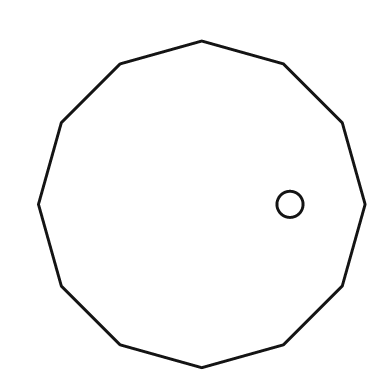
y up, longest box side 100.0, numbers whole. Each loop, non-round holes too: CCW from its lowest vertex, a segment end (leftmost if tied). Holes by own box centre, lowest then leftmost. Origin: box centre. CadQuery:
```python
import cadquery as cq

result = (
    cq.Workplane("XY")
    .moveTo(0.0, -50.0)
    .lineTo(25.0, -43.0)
    .lineTo(43.0, -25.0)
    .lineTo(50.0, 0.0)
    .lineTo(43.0, 25.0)
    .lineTo(25.0, 43.0)
    .lineTo(0.0, 50.0)
    .lineTo(-25.0, 43.0)
    .lineTo(-43.0, 25.0)
    .lineTo(-50.0, 0.0)
    .lineTo(-43.0, -25.0)
    .lineTo(-25.0, -43.0)
    .close()
    .moveTo(27.0, 0.0)
    .circle(4.0)
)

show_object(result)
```